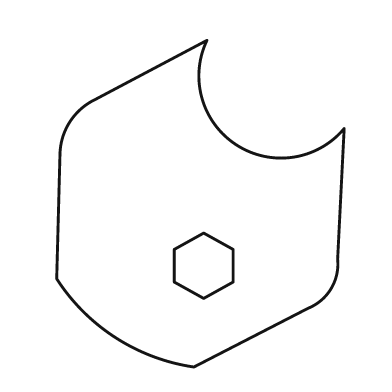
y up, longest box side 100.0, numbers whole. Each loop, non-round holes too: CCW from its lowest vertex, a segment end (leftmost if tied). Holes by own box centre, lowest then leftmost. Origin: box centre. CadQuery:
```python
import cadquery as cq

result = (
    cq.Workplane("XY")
    .moveTo(-2.0, -50.0)
    .lineTo(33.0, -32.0)
    .threePointArc((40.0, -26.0), (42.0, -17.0))
    .lineTo(44.0, 23.0)
    .threePointArc((11.0, 18.0), (2.0, 50.0))
    .lineTo(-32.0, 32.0)
    .threePointArc((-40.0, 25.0), (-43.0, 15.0))
    .lineTo(-44.0, -23.0)
    .threePointArc((-26.0, -41.0), (-2.0, -50.0))
    .close()
    .moveTo(1.0, -29.0)
    .lineTo(10.0, -24.0)
    .lineTo(10.0, -14.0)
    .lineTo(1.0, -9.0)
    .lineTo(-8.0, -14.0)
    .lineTo(-8.0, -24.0)
    .close()
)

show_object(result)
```